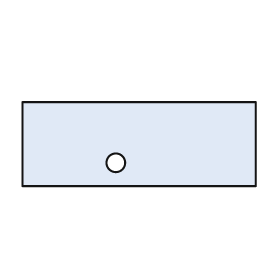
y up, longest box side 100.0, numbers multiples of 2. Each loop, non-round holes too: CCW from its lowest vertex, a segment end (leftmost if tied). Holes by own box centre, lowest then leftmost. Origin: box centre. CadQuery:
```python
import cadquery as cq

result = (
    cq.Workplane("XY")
    .moveTo(-50.0, -18.0)
    .lineTo(50.0, -18.0)
    .lineTo(50.0, 18.0)
    .lineTo(-50.0, 18.0)
    .close()
    .moveTo(-10.0, -8.0)
    .circle(4.0)
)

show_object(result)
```